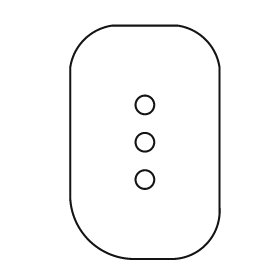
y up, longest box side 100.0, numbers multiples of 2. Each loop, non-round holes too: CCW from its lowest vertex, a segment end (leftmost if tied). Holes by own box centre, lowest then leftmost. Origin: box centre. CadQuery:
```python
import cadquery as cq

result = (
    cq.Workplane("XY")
    .moveTo(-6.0, -50.0)
    .lineTo(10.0, -50.0)
    .threePointArc((26.0, -44.0), (32.0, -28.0))
    .lineTo(32.0, 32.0)
    .threePointArc((26.0, 44.0), (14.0, 50.0))
    .lineTo(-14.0, 50.0)
    .threePointArc((-26.0, 44.0), (-32.0, 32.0))
    .lineTo(-32.0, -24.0)
    .threePointArc((-24.0, -42.0), (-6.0, -50.0))
    .close()
    .moveTo(0.0, -16.0)
    .circle(4.0)
    .moveTo(0.0, 0.0)
    .circle(4.0)
    .moveTo(0.0, 16.0)
    .circle(4.0)
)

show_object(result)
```